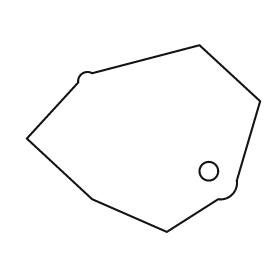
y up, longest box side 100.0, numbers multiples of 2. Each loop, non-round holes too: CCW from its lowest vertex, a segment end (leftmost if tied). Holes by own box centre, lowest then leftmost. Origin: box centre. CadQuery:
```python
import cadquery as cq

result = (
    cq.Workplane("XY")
    .moveTo(10.0, -40.0)
    .lineTo(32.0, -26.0)
    .threePointArc((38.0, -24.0), (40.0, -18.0))
    .lineTo(50.0, 16.0)
    .lineTo(24.0, 40.0)
    .lineTo(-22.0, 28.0)
    .threePointArc((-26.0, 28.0), (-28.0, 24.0))
    .lineTo(-50.0, 0.0)
    .lineTo(-22.0, -26.0)
    .close()
    .moveTo(28.0, -14.0)
    .circle(4.0)
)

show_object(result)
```